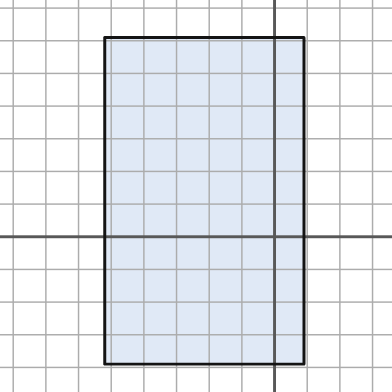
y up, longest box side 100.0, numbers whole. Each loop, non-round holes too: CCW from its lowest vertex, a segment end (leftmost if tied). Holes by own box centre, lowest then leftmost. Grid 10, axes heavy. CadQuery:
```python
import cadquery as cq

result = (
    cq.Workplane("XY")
    .moveTo(-52.0, -39.0)
    .lineTo(9.0, -39.0)
    .lineTo(9.0, 61.0)
    .lineTo(-52.0, 61.0)
    .close()
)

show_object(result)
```